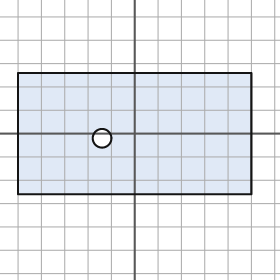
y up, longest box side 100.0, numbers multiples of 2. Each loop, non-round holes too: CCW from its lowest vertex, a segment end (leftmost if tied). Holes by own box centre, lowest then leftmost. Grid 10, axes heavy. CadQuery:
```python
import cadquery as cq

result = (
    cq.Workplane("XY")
    .moveTo(-50.0, -26.0)
    .lineTo(50.0, -26.0)
    .lineTo(50.0, 26.0)
    .lineTo(-50.0, 26.0)
    .close()
    .moveTo(-14.0, -2.0)
    .circle(4.0)
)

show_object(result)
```